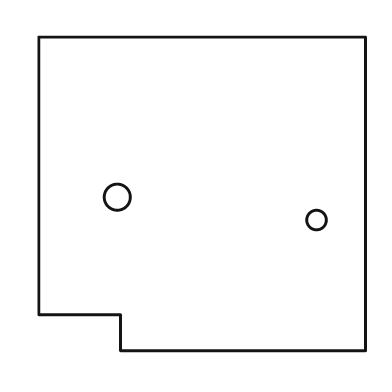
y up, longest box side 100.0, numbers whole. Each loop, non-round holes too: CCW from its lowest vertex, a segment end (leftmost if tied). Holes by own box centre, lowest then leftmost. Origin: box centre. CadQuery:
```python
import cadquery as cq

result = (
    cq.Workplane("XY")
    .moveTo(-25.0, -48.0)
    .lineTo(50.0, -48.0)
    .lineTo(50.0, 48.0)
    .lineTo(-50.0, 48.0)
    .lineTo(-50.0, -37.0)
    .lineTo(-25.0, -37.0)
    .close()
    .moveTo(35.0, -8.0)
    .circle(3.0)
    .moveTo(-26.0, -1.0)
    .circle(4.0)
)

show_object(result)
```